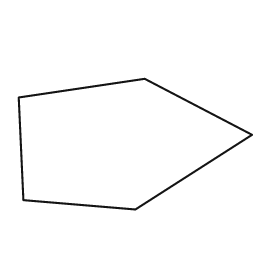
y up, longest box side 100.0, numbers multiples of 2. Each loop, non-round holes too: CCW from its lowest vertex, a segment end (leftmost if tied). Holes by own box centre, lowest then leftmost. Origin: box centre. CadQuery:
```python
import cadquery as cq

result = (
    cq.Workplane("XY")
    .moveTo(0.0, -28.0)
    .lineTo(50.0, 4.0)
    .lineTo(4.0, 28.0)
    .lineTo(-50.0, 20.0)
    .lineTo(-48.0, -24.0)
    .close()
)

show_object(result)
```